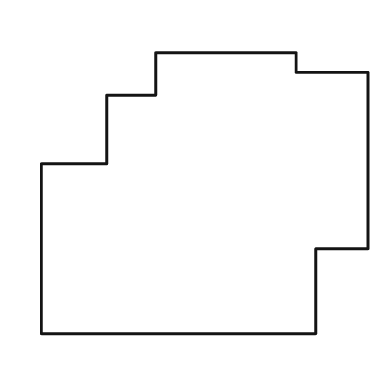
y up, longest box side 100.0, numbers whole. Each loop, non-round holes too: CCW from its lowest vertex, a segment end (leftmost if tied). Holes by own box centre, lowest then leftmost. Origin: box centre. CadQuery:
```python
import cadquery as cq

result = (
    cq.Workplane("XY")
    .moveTo(-50.0, -43.0)
    .lineTo(34.0, -43.0)
    .lineTo(34.0, -17.0)
    .lineTo(50.0, -17.0)
    .lineTo(50.0, 37.0)
    .lineTo(28.0, 37.0)
    .lineTo(28.0, 43.0)
    .lineTo(-15.0, 43.0)
    .lineTo(-15.0, 30.0)
    .lineTo(-30.0, 30.0)
    .lineTo(-30.0, 9.0)
    .lineTo(-50.0, 9.0)
    .close()
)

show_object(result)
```